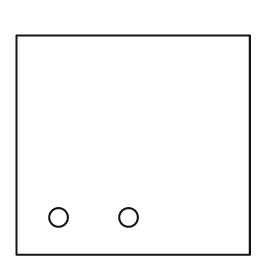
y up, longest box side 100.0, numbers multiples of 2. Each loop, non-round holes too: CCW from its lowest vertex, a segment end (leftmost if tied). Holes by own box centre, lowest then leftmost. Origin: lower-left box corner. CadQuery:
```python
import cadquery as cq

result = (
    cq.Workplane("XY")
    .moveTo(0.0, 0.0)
    .lineTo(100.0, 0.0)
    .lineTo(100.0, 94.0)
    .lineTo(0.0, 94.0)
    .close()
    .moveTo(18.0, 16.0)
    .circle(4.0)
    .moveTo(48.0, 16.0)
    .circle(4.0)
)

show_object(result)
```